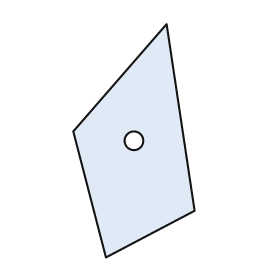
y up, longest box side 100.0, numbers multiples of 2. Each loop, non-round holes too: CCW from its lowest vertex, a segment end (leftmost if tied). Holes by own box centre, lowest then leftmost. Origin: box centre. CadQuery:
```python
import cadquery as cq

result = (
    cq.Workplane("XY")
    .moveTo(-12.0, -50.0)
    .lineTo(26.0, -30.0)
    .lineTo(14.0, 50.0)
    .lineTo(-26.0, 4.0)
    .close()
    .moveTo(0.0, 0.0)
    .circle(4.0)
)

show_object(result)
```